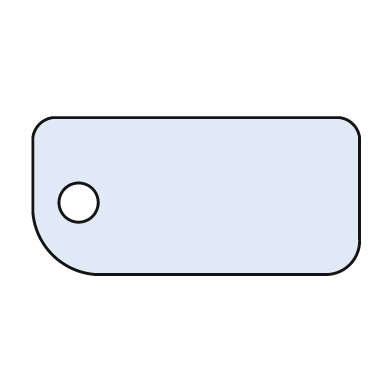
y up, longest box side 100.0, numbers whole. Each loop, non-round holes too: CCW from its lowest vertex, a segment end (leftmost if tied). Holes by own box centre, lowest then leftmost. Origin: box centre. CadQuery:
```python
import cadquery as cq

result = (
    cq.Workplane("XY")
    .moveTo(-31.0, -24.0)
    .lineTo(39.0, -24.0)
    .threePointArc((47.0, -21.0), (50.0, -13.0))
    .lineTo(50.0, 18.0)
    .threePointArc((48.0, 22.0), (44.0, 24.0))
    .lineTo(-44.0, 24.0)
    .threePointArc((-48.0, 22.0), (-50.0, 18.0))
    .lineTo(-50.0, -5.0)
    .threePointArc((-44.0, -18.0), (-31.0, -24.0))
    .close()
    .moveTo(-36.0, -2.0)
    .circle(6.0)
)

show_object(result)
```